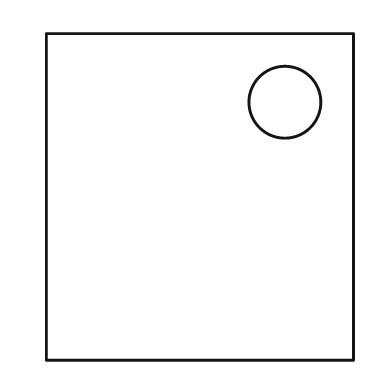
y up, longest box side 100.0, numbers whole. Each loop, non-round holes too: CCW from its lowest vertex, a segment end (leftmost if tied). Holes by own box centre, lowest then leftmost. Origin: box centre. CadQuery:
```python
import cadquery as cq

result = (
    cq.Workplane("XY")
    .moveTo(-47.0, -50.0)
    .lineTo(47.0, -50.0)
    .lineTo(47.0, 50.0)
    .lineTo(-47.0, 50.0)
    .close()
    .moveTo(26.0, 29.0)
    .circle(11.0)
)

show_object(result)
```